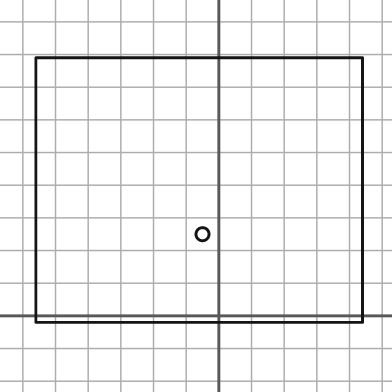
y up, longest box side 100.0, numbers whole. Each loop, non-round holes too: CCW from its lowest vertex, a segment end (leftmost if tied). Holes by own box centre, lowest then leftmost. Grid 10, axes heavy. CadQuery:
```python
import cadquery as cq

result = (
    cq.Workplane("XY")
    .moveTo(-56.0, -2.0)
    .lineTo(44.0, -2.0)
    .lineTo(44.0, 79.0)
    .lineTo(-56.0, 79.0)
    .close()
    .moveTo(-5.0, 25.0)
    .circle(2.0)
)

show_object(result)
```